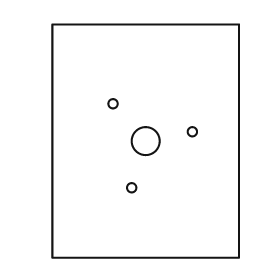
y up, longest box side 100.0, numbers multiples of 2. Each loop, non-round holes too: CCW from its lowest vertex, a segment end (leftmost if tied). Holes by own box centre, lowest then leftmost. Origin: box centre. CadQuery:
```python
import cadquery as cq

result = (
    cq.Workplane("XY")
    .moveTo(-40.0, -50.0)
    .lineTo(40.0, -50.0)
    .lineTo(40.0, 50.0)
    .lineTo(-40.0, 50.0)
    .close()
    .moveTo(-6.0, -20.0)
    .circle(2.0)
    .moveTo(0.0, 0.0)
    .circle(6.0)
    .moveTo(20.0, 4.0)
    .circle(2.0)
    .moveTo(-14.0, 16.0)
    .circle(2.0)
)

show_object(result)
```